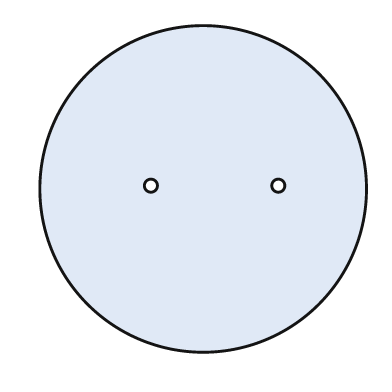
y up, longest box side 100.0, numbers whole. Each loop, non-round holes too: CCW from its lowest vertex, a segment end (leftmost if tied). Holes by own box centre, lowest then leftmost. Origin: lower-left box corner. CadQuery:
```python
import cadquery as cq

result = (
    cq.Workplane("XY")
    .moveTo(50.0, 50.0)
    .circle(50.0)
    .moveTo(34.0, 51.0)
    .circle(2.0)
    .moveTo(73.0, 51.0)
    .circle(2.0)
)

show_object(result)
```